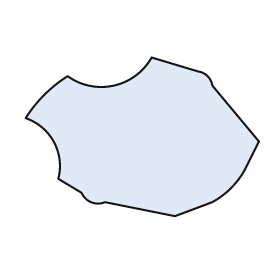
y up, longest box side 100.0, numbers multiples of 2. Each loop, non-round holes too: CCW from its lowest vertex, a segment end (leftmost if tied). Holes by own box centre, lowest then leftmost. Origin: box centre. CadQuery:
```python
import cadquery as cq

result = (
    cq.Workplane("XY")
    .moveTo(14.0, -34.0)
    .lineTo(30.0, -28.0)
    .threePointArc((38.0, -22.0), (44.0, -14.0))
    .lineTo(50.0, -2.0)
    .lineTo(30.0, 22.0)
    .threePointArc((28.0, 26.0), (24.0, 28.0))
    .lineTo(4.0, 34.0)
    .threePointArc((-12.0, 22.0), (-32.0, 26.0))
    .threePointArc((-42.0, 18.0), (-50.0, 8.0))
    .threePointArc((-38.0, -2.0), (-36.0, -18.0))
    .lineTo(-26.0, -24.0)
    .threePointArc((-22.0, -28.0), (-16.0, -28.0))
    .close()
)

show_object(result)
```